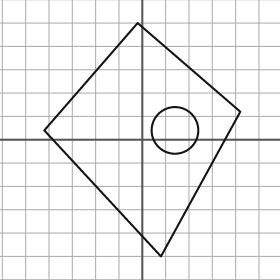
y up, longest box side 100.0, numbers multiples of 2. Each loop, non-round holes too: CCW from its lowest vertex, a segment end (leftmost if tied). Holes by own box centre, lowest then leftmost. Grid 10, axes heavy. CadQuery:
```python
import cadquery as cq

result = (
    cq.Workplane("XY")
    .moveTo(8.0, -50.0)
    .lineTo(42.0, 12.0)
    .lineTo(-2.0, 50.0)
    .lineTo(-42.0, 4.0)
    .close()
    .moveTo(14.0, 4.0)
    .circle(10.0)
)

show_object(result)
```